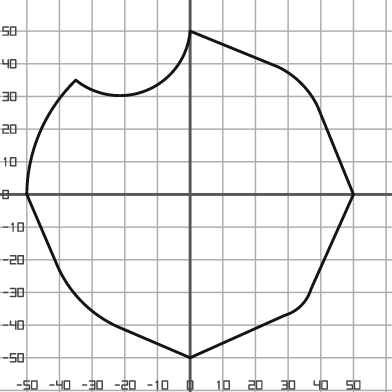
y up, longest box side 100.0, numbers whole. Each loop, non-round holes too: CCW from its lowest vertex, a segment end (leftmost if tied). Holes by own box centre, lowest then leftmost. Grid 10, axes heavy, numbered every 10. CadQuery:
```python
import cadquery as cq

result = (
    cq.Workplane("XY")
    .moveTo(0.0, -50.0)
    .lineTo(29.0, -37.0)
    .threePointArc((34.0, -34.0), (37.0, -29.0))
    .lineTo(50.0, 0.0)
    .lineTo(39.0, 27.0)
    .threePointArc((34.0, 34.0), (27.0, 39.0))
    .lineTo(0.0, 50.0)
    .threePointArc((-13.0, 32.0), (-35.0, 35.0))
    .threePointArc((-46.0, 19.0), (-50.0, 0.0))
    .lineTo(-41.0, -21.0)
    .threePointArc((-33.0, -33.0), (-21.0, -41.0))
    .close()
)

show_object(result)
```